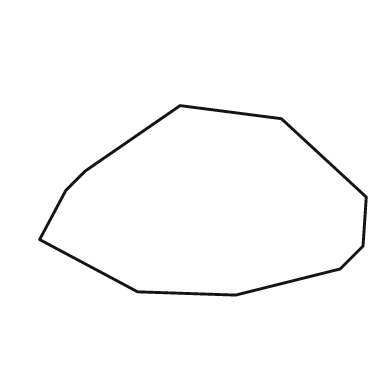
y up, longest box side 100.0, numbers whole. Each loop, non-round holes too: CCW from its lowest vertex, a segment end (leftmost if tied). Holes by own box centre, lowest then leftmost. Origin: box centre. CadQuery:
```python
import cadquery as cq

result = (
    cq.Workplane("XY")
    .moveTo(10.0, -29.0)
    .lineTo(42.0, -21.0)
    .lineTo(49.0, -14.0)
    .lineTo(50.0, 1.0)
    .lineTo(24.0, 25.0)
    .lineTo(-7.0, 29.0)
    .lineTo(-36.0, 9.0)
    .lineTo(-42.0, 3.0)
    .lineTo(-50.0, -12.0)
    .lineTo(-20.0, -28.0)
    .close()
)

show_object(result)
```